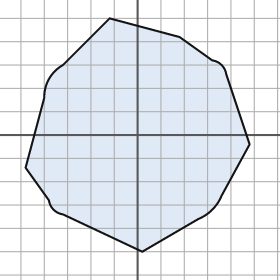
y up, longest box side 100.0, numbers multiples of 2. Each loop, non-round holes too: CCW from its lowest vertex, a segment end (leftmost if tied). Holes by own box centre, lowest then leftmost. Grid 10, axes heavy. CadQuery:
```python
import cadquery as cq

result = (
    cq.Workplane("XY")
    .moveTo(2.0, -50.0)
    .lineTo(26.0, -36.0)
    .threePointArc((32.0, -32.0), (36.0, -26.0))
    .lineTo(48.0, -4.0)
    .lineTo(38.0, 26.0)
    .threePointArc((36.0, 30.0), (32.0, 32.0))
    .lineTo(18.0, 42.0)
    .lineTo(-12.0, 50.0)
    .lineTo(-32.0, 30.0)
    .threePointArc((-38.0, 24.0), (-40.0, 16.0))
    .lineTo(-48.0, -14.0)
    .lineTo(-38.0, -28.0)
    .threePointArc((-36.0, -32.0), (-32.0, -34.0))
    .close()
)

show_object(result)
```